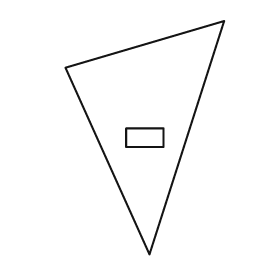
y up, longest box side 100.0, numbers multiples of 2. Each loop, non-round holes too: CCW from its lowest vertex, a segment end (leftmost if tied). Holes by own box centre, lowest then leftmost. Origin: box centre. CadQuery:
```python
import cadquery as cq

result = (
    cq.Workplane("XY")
    .moveTo(2.0, -50.0)
    .lineTo(34.0, 50.0)
    .lineTo(-34.0, 30.0)
    .close()
    .moveTo(-8.0, -4.0)
    .lineTo(8.0, -4.0)
    .lineTo(8.0, 4.0)
    .lineTo(-8.0, 4.0)
    .close()
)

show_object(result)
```